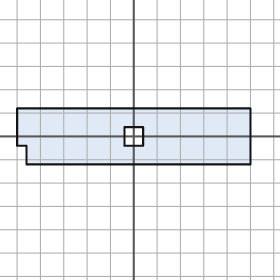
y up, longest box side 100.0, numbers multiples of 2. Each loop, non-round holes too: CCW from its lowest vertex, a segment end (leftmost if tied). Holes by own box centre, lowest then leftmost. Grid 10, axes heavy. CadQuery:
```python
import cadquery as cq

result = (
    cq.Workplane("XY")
    .moveTo(-46.0, -12.0)
    .lineTo(50.0, -12.0)
    .lineTo(50.0, 12.0)
    .lineTo(-50.0, 12.0)
    .lineTo(-50.0, -4.0)
    .lineTo(-46.0, -4.0)
    .close()
    .moveTo(-4.0, -4.0)
    .lineTo(4.0, -4.0)
    .lineTo(4.0, 4.0)
    .lineTo(-4.0, 4.0)
    .close()
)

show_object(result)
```